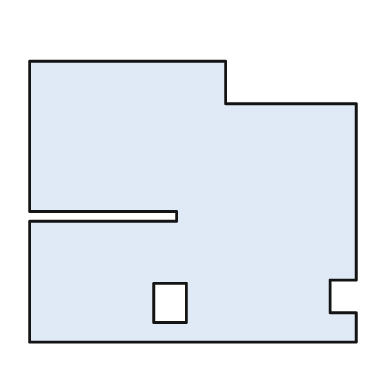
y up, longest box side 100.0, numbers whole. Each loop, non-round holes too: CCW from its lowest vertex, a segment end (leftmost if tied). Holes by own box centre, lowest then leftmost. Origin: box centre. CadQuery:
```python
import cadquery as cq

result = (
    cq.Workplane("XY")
    .moveTo(-50.0, -43.0)
    .lineTo(50.0, -43.0)
    .lineTo(50.0, -34.0)
    .lineTo(42.0, -34.0)
    .lineTo(42.0, -24.0)
    .lineTo(50.0, -24.0)
    .lineTo(50.0, 30.0)
    .lineTo(10.0, 30.0)
    .lineTo(10.0, 43.0)
    .lineTo(-50.0, 43.0)
    .lineTo(-50.0, -3.0)
    .lineTo(-5.0, -3.0)
    .lineTo(-5.0, -6.0)
    .lineTo(-50.0, -6.0)
    .close()
    .moveTo(-12.0, -37.0)
    .lineTo(-2.0, -37.0)
    .lineTo(-2.0, -25.0)
    .lineTo(-12.0, -25.0)
    .close()
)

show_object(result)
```